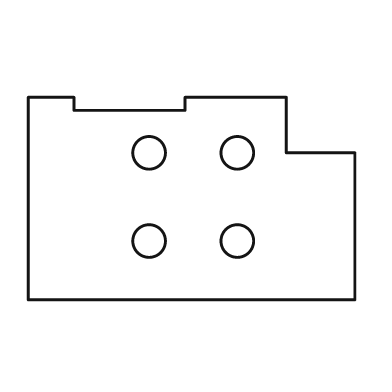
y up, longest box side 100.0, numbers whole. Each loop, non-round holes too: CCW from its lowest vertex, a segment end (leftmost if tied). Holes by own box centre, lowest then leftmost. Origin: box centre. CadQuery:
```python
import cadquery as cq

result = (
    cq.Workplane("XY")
    .moveTo(-50.0, -31.0)
    .lineTo(50.0, -31.0)
    .lineTo(50.0, 14.0)
    .lineTo(29.0, 14.0)
    .lineTo(29.0, 31.0)
    .lineTo(-2.0, 31.0)
    .lineTo(-2.0, 27.0)
    .lineTo(-36.0, 27.0)
    .lineTo(-36.0, 31.0)
    .lineTo(-50.0, 31.0)
    .close()
    .moveTo(-13.0, -13.0)
    .circle(5.0)
    .moveTo(14.0, -13.0)
    .circle(5.0)
    .moveTo(-13.0, 14.0)
    .circle(5.0)
    .moveTo(14.0, 14.0)
    .circle(5.0)
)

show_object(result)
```